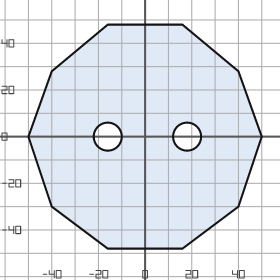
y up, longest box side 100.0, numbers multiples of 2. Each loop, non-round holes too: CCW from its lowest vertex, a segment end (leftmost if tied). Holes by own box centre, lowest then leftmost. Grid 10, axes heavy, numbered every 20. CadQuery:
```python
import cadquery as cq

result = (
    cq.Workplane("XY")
    .moveTo(-16.0, -48.0)
    .lineTo(16.0, -48.0)
    .lineTo(40.0, -30.0)
    .lineTo(50.0, 0.0)
    .lineTo(40.0, 28.0)
    .lineTo(16.0, 48.0)
    .lineTo(-16.0, 48.0)
    .lineTo(-40.0, 28.0)
    .lineTo(-50.0, 0.0)
    .lineTo(-40.0, -30.0)
    .close()
    .moveTo(-16.0, 0.0)
    .circle(6.0)
    .moveTo(18.0, 0.0)
    .circle(6.0)
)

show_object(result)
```